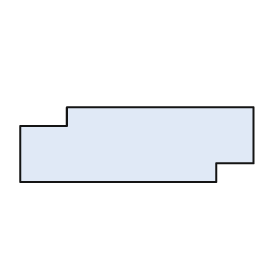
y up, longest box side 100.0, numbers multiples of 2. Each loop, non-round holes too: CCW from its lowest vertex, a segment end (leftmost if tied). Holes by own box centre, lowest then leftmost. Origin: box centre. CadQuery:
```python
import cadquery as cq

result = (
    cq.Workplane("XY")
    .moveTo(-50.0, -16.0)
    .lineTo(34.0, -16.0)
    .lineTo(34.0, -8.0)
    .lineTo(50.0, -8.0)
    .lineTo(50.0, 16.0)
    .lineTo(-30.0, 16.0)
    .lineTo(-30.0, 8.0)
    .lineTo(-50.0, 8.0)
    .close()
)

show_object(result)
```